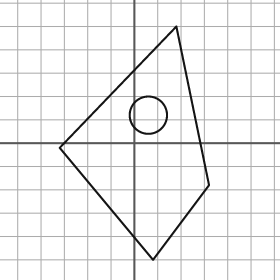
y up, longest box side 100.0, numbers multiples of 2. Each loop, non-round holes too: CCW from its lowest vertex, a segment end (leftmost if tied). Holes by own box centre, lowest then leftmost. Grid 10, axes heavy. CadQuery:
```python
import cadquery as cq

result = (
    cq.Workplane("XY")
    .moveTo(8.0, -50.0)
    .lineTo(32.0, -18.0)
    .lineTo(18.0, 50.0)
    .lineTo(-32.0, -2.0)
    .close()
    .moveTo(6.0, 12.0)
    .circle(8.0)
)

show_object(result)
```